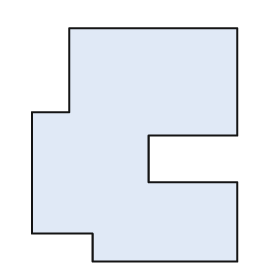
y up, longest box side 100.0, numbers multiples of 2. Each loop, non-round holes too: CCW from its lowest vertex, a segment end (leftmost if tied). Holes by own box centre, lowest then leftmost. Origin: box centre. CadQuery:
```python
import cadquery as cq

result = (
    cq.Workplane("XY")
    .moveTo(-18.0, -50.0)
    .lineTo(44.0, -50.0)
    .lineTo(44.0, -16.0)
    .lineTo(6.0, -16.0)
    .lineTo(6.0, 4.0)
    .lineTo(44.0, 4.0)
    .lineTo(44.0, 50.0)
    .lineTo(-28.0, 50.0)
    .lineTo(-28.0, 14.0)
    .lineTo(-44.0, 14.0)
    .lineTo(-44.0, -38.0)
    .lineTo(-18.0, -38.0)
    .close()
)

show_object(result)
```